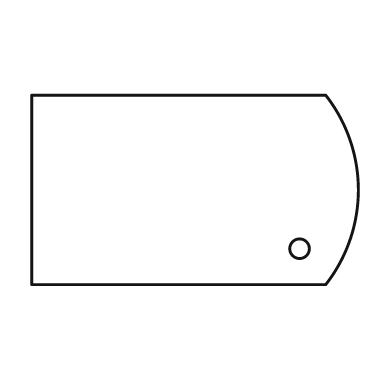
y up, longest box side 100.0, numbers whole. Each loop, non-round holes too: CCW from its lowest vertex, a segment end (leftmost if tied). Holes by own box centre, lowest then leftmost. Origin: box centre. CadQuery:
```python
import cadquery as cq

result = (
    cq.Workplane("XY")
    .moveTo(-50.0, -29.0)
    .lineTo(40.0, -29.0)
    .threePointArc((50.0, 0.0), (40.0, 29.0))
    .lineTo(-50.0, 29.0)
    .close()
    .moveTo(32.0, -18.0)
    .circle(3.0)
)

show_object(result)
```